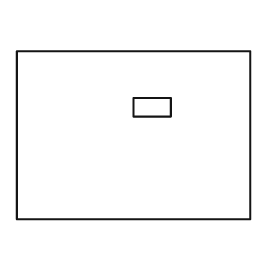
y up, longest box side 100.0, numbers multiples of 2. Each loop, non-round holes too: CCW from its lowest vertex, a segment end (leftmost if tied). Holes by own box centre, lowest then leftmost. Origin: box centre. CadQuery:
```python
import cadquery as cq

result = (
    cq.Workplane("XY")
    .moveTo(-50.0, -36.0)
    .lineTo(50.0, -36.0)
    .lineTo(50.0, 36.0)
    .lineTo(-50.0, 36.0)
    .close()
    .moveTo(0.0, 8.0)
    .lineTo(16.0, 8.0)
    .lineTo(16.0, 16.0)
    .lineTo(0.0, 16.0)
    .close()
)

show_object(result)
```